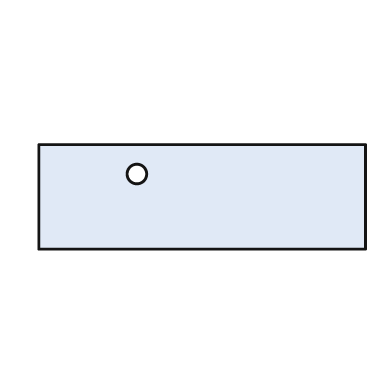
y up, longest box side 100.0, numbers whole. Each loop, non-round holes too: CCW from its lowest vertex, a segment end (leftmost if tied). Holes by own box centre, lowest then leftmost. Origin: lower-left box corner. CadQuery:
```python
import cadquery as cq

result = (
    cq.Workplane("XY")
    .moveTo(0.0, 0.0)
    .lineTo(100.0, 0.0)
    .lineTo(100.0, 32.0)
    .lineTo(0.0, 32.0)
    .close()
    .moveTo(30.0, 23.0)
    .circle(3.0)
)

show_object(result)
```